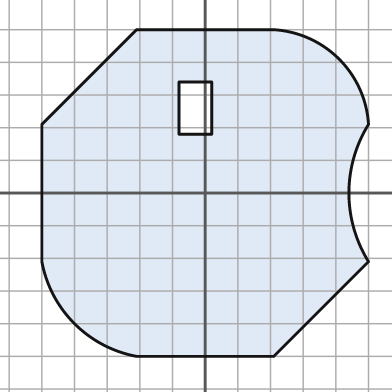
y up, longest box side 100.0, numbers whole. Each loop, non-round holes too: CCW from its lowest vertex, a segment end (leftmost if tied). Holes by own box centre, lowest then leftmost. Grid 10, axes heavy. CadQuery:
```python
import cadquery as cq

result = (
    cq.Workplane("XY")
    .moveTo(-21.0, -50.0)
    .lineTo(21.0, -50.0)
    .lineTo(50.0, -21.0)
    .threePointArc((44.0, 0.0), (50.0, 21.0))
    .threePointArc((41.0, 41.0), (21.0, 50.0))
    .lineTo(-21.0, 50.0)
    .lineTo(-50.0, 21.0)
    .lineTo(-50.0, -21.0)
    .threePointArc((-40.0, -40.0), (-21.0, -50.0))
    .close()
    .moveTo(-8.0, 18.0)
    .lineTo(2.0, 18.0)
    .lineTo(2.0, 34.0)
    .lineTo(-8.0, 34.0)
    .close()
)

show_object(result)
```